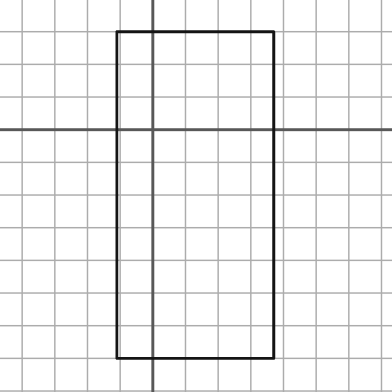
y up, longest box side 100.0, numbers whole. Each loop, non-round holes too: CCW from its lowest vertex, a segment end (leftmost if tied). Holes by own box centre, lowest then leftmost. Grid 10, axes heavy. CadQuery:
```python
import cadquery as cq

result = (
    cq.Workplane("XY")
    .moveTo(-11.0, -70.0)
    .lineTo(37.0, -70.0)
    .lineTo(37.0, 30.0)
    .lineTo(-11.0, 30.0)
    .close()
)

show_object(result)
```